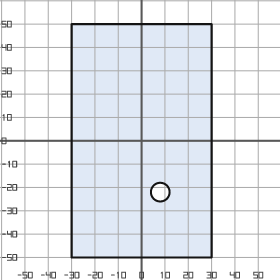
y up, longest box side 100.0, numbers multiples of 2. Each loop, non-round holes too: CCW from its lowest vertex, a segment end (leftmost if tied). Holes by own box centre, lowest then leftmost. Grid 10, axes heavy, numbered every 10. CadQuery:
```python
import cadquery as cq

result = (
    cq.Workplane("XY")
    .moveTo(-30.0, -50.0)
    .lineTo(30.0, -50.0)
    .lineTo(30.0, 50.0)
    .lineTo(-30.0, 50.0)
    .close()
    .moveTo(8.0, -22.0)
    .circle(4.0)
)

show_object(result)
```